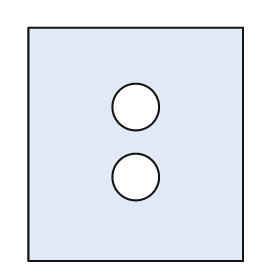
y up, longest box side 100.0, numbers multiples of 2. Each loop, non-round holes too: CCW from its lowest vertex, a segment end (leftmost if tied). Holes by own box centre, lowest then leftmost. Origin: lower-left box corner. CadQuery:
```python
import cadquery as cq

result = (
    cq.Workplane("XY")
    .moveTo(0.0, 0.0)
    .lineTo(92.0, 0.0)
    .lineTo(92.0, 100.0)
    .lineTo(0.0, 100.0)
    .close()
    .moveTo(46.0, 36.0)
    .circle(10.0)
    .moveTo(46.0, 66.0)
    .circle(10.0)
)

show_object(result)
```